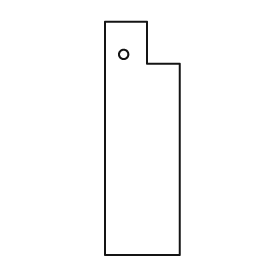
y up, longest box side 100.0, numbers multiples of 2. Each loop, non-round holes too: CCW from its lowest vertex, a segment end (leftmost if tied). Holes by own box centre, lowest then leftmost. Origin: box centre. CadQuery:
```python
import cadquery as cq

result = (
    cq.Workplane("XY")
    .moveTo(-16.0, -50.0)
    .lineTo(16.0, -50.0)
    .lineTo(16.0, 32.0)
    .lineTo(2.0, 32.0)
    .lineTo(2.0, 50.0)
    .lineTo(-16.0, 50.0)
    .close()
    .moveTo(-8.0, 36.0)
    .circle(2.0)
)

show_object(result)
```